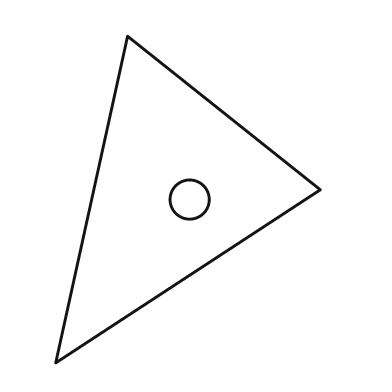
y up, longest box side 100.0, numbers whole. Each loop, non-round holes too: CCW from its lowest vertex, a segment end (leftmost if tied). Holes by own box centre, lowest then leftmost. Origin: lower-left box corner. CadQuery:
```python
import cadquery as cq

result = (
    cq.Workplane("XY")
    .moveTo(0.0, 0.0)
    .lineTo(81.0, 53.0)
    .lineTo(22.0, 100.0)
    .close()
    .moveTo(41.0, 50.0)
    .circle(6.0)
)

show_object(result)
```